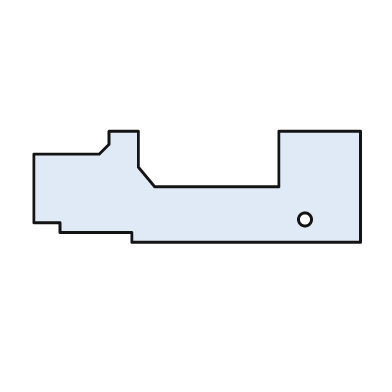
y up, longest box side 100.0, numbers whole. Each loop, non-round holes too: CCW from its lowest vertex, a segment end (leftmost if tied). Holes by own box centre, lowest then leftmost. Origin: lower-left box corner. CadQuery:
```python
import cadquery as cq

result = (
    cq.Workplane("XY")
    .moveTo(30.0, 0.0)
    .lineTo(100.0, 0.0)
    .lineTo(100.0, 34.0)
    .lineTo(75.0, 34.0)
    .lineTo(75.0, 17.0)
    .lineTo(37.0, 17.0)
    .lineTo(32.0, 23.0)
    .lineTo(32.0, 34.0)
    .lineTo(23.0, 34.0)
    .lineTo(23.0, 30.0)
    .lineTo(20.0, 27.0)
    .lineTo(0.0, 27.0)
    .lineTo(0.0, 6.0)
    .lineTo(8.0, 6.0)
    .lineTo(8.0, 3.0)
    .lineTo(30.0, 3.0)
    .close()
    .moveTo(83.0, 7.0)
    .circle(2.0)
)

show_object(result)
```